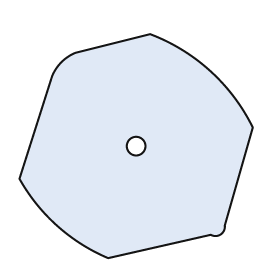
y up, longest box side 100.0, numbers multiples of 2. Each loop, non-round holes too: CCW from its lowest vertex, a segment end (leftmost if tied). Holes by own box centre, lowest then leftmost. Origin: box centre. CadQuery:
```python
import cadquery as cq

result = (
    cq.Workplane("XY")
    .moveTo(-12.0, -48.0)
    .lineTo(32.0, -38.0)
    .threePointArc((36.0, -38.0), (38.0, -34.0))
    .lineTo(50.0, 8.0)
    .threePointArc((32.0, 32.0), (6.0, 48.0))
    .lineTo(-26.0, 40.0)
    .threePointArc((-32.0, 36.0), (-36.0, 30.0))
    .lineTo(-50.0, -14.0)
    .threePointArc((-34.0, -34.0), (-12.0, -48.0))
    .close()
    .moveTo(0.0, 0.0)
    .circle(4.0)
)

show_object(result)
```